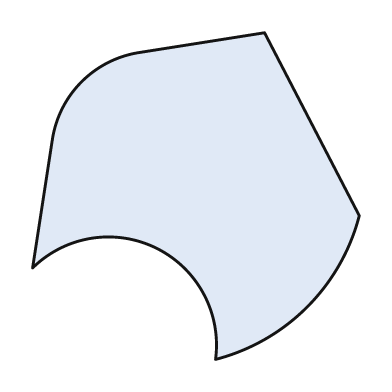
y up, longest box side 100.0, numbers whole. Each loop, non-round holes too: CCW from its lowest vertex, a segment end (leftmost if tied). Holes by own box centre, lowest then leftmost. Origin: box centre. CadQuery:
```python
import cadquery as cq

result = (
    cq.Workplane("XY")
    .moveTo(6.0, -50.0)
    .threePointArc((34.0, -34.0), (50.0, -6.0))
    .lineTo(21.0, 50.0)
    .lineTo(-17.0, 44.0)
    .threePointArc((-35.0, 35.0), (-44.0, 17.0))
    .lineTo(-50.0, -22.0)
    .threePointArc((-12.0, -16.0), (6.0, -50.0))
    .close()
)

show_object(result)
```